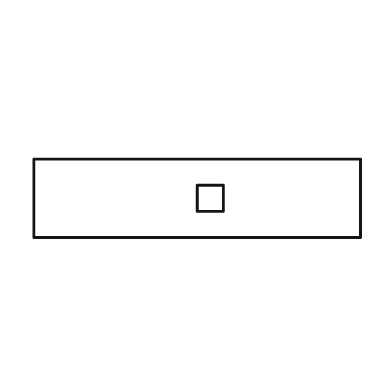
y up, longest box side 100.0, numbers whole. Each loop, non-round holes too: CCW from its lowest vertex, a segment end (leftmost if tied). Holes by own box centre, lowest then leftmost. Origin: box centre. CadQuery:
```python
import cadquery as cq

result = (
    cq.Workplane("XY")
    .moveTo(-50.0, -12.0)
    .lineTo(50.0, -12.0)
    .lineTo(50.0, 12.0)
    .lineTo(-50.0, 12.0)
    .close()
    .moveTo(0.0, -4.0)
    .lineTo(8.0, -4.0)
    .lineTo(8.0, 4.0)
    .lineTo(0.0, 4.0)
    .close()
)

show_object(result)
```